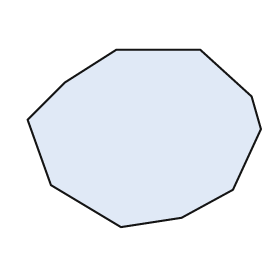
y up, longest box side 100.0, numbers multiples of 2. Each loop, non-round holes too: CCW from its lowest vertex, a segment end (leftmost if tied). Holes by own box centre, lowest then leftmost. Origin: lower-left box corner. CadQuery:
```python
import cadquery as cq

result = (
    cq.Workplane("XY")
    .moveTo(40.0, 0.0)
    .lineTo(66.0, 4.0)
    .lineTo(88.0, 16.0)
    .lineTo(100.0, 42.0)
    .lineTo(96.0, 56.0)
    .lineTo(74.0, 76.0)
    .lineTo(38.0, 76.0)
    .lineTo(16.0, 62.0)
    .lineTo(0.0, 46.0)
    .lineTo(10.0, 18.0)
    .close()
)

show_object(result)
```